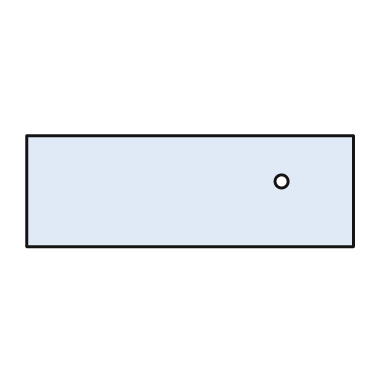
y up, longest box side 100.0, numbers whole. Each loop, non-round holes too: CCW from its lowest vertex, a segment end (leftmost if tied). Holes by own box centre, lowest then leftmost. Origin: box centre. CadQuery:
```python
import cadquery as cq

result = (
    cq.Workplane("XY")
    .moveTo(-50.0, -17.0)
    .lineTo(50.0, -17.0)
    .lineTo(50.0, 17.0)
    .lineTo(-50.0, 17.0)
    .close()
    .moveTo(28.0, 3.0)
    .circle(2.0)
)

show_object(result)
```